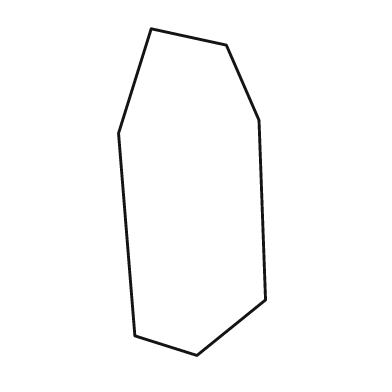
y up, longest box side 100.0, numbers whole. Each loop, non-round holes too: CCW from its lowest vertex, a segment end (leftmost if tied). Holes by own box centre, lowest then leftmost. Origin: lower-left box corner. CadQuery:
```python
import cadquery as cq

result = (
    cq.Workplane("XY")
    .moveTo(24.0, 0.0)
    .lineTo(45.0, 17.0)
    .lineTo(43.0, 72.0)
    .lineTo(33.0, 95.0)
    .lineTo(10.0, 100.0)
    .lineTo(0.0, 68.0)
    .lineTo(5.0, 6.0)
    .close()
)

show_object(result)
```